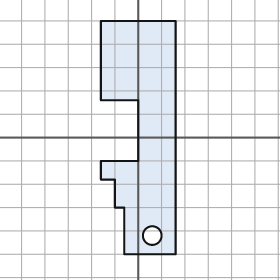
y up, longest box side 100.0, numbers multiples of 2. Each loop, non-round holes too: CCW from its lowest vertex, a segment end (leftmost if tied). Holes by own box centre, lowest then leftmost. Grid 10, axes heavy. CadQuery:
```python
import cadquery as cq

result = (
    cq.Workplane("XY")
    .moveTo(-6.0, -50.0)
    .lineTo(16.0, -50.0)
    .lineTo(16.0, 50.0)
    .lineTo(-16.0, 50.0)
    .lineTo(-16.0, 16.0)
    .lineTo(0.0, 16.0)
    .lineTo(0.0, -10.0)
    .lineTo(-16.0, -10.0)
    .lineTo(-16.0, -18.0)
    .lineTo(-10.0, -18.0)
    .lineTo(-10.0, -30.0)
    .lineTo(-6.0, -30.0)
    .close()
    .moveTo(6.0, -42.0)
    .circle(4.0)
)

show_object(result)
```